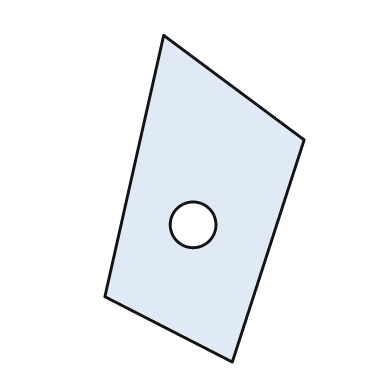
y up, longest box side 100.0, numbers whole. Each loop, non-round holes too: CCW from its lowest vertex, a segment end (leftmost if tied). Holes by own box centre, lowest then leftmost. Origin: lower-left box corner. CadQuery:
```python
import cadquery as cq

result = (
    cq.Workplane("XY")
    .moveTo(39.0, 0.0)
    .lineTo(61.0, 68.0)
    .lineTo(18.0, 100.0)
    .lineTo(0.0, 20.0)
    .close()
    .moveTo(27.0, 42.0)
    .circle(7.0)
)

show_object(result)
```